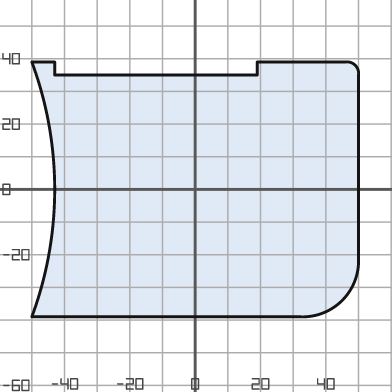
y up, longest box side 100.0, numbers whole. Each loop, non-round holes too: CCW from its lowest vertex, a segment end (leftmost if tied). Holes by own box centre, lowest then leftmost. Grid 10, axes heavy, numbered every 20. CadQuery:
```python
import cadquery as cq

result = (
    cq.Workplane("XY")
    .moveTo(-50.0, -39.0)
    .lineTo(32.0, -39.0)
    .threePointArc((45.0, -34.0), (50.0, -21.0))
    .lineTo(50.0, 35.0)
    .threePointArc((49.0, 38.0), (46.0, 39.0))
    .lineTo(19.0, 39.0)
    .lineTo(19.0, 35.0)
    .lineTo(-43.0, 35.0)
    .lineTo(-43.0, 39.0)
    .lineTo(-50.0, 39.0)
    .threePointArc((-43.0, 0.0), (-50.0, -39.0))
    .close()
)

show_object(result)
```